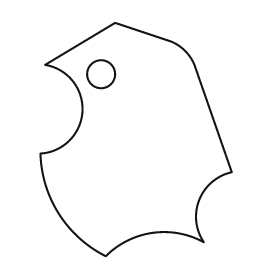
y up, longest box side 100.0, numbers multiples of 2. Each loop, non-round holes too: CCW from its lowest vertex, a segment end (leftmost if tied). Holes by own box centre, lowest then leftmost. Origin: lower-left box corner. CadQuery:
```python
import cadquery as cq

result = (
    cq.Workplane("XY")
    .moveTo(28.0, 0.0)
    .threePointArc((48.0, 10.0), (70.0, 6.0))
    .threePointArc((68.0, 24.0), (82.0, 36.0))
    .lineTo(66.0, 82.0)
    .threePointArc((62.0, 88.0), (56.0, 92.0))
    .lineTo(32.0, 100.0)
    .lineTo(2.0, 82.0)
    .threePointArc((18.0, 62.0), (0.0, 44.0))
    .threePointArc((8.0, 18.0), (28.0, 0.0))
    .close()
    .moveTo(26.0, 78.0)
    .circle(6.0)
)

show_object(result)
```